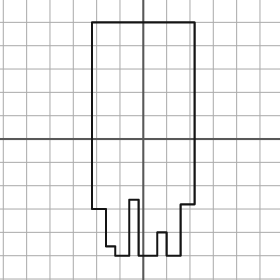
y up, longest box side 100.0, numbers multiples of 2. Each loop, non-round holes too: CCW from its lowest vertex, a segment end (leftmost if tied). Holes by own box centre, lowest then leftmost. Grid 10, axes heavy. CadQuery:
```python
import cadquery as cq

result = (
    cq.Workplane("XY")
    .moveTo(-12.0, -50.0)
    .lineTo(-6.0, -50.0)
    .lineTo(-6.0, -26.0)
    .lineTo(-2.0, -26.0)
    .lineTo(-2.0, -50.0)
    .lineTo(6.0, -50.0)
    .lineTo(6.0, -40.0)
    .lineTo(10.0, -40.0)
    .lineTo(10.0, -50.0)
    .lineTo(16.0, -50.0)
    .lineTo(16.0, -28.0)
    .lineTo(22.0, -28.0)
    .lineTo(22.0, 50.0)
    .lineTo(-22.0, 50.0)
    .lineTo(-22.0, -30.0)
    .lineTo(-16.0, -30.0)
    .lineTo(-16.0, -46.0)
    .lineTo(-12.0, -46.0)
    .close()
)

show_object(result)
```